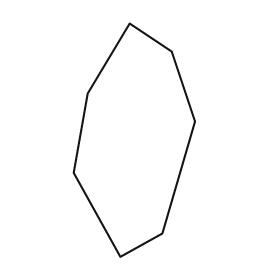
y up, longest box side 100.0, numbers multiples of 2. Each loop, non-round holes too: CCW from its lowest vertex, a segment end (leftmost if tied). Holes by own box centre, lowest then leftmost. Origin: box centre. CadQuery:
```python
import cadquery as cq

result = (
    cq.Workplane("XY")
    .moveTo(-6.0, -50.0)
    .lineTo(12.0, -40.0)
    .lineTo(26.0, 8.0)
    .lineTo(16.0, 38.0)
    .lineTo(-2.0, 50.0)
    .lineTo(-20.0, 20.0)
    .lineTo(-26.0, -14.0)
    .close()
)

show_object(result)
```